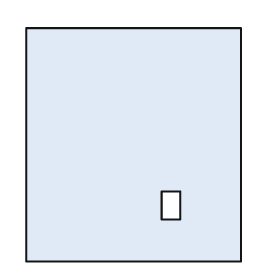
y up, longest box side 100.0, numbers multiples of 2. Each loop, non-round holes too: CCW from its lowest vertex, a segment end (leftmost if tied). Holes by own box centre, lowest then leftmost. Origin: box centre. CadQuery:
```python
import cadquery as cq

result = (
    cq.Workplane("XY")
    .moveTo(-46.0, -50.0)
    .lineTo(46.0, -50.0)
    .lineTo(46.0, 50.0)
    .lineTo(-46.0, 50.0)
    .close()
    .moveTo(12.0, -32.0)
    .lineTo(20.0, -32.0)
    .lineTo(20.0, -20.0)
    .lineTo(12.0, -20.0)
    .close()
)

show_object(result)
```